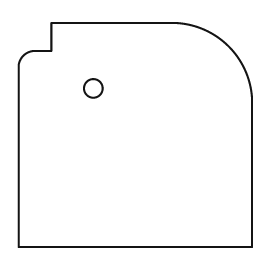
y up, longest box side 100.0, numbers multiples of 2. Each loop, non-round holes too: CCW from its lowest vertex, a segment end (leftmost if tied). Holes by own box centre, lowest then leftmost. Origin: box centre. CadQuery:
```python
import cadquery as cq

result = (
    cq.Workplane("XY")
    .moveTo(-50.0, -48.0)
    .lineTo(50.0, -48.0)
    .lineTo(50.0, 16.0)
    .threePointArc((40.0, 38.0), (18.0, 48.0))
    .lineTo(-36.0, 48.0)
    .lineTo(-36.0, 36.0)
    .lineTo(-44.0, 36.0)
    .threePointArc((-48.0, 34.0), (-50.0, 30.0))
    .close()
    .moveTo(-18.0, 20.0)
    .circle(4.0)
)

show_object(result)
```